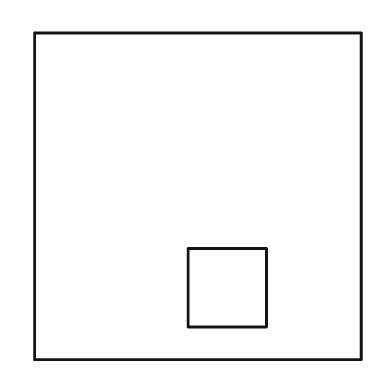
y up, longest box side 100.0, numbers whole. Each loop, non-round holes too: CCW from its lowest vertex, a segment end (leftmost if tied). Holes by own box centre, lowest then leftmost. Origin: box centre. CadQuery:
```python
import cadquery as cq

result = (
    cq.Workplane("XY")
    .moveTo(-50.0, -50.0)
    .lineTo(50.0, -50.0)
    .lineTo(50.0, 50.0)
    .lineTo(-50.0, 50.0)
    .close()
    .moveTo(-3.0, -40.0)
    .lineTo(21.0, -40.0)
    .lineTo(21.0, -16.0)
    .lineTo(-3.0, -16.0)
    .close()
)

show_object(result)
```